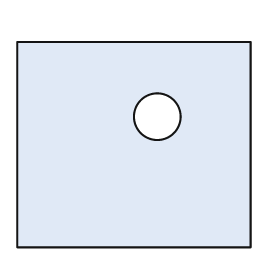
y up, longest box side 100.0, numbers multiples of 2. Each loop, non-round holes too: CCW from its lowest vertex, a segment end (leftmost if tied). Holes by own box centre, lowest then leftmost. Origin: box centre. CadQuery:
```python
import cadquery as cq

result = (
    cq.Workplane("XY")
    .moveTo(-50.0, -44.0)
    .lineTo(50.0, -44.0)
    .lineTo(50.0, 44.0)
    .lineTo(-50.0, 44.0)
    .close()
    .moveTo(10.0, 12.0)
    .circle(10.0)
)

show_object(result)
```